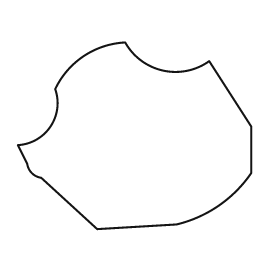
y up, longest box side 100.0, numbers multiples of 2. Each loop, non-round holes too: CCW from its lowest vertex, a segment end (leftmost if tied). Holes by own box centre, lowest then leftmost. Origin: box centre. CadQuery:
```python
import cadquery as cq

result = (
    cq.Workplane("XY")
    .moveTo(-16.0, -40.0)
    .lineTo(18.0, -38.0)
    .threePointArc((36.0, -30.0), (50.0, -16.0))
    .lineTo(50.0, 4.0)
    .lineTo(32.0, 32.0)
    .threePointArc((12.0, 28.0), (-4.0, 40.0))
    .threePointArc((-22.0, 34.0), (-34.0, 20.0))
    .threePointArc((-36.0, 4.0), (-50.0, -4.0))
    .lineTo(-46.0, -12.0)
    .threePointArc((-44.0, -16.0), (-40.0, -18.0))
    .close()
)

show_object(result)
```